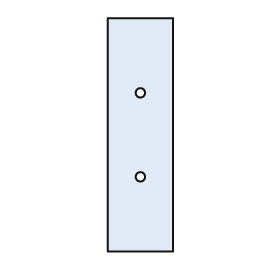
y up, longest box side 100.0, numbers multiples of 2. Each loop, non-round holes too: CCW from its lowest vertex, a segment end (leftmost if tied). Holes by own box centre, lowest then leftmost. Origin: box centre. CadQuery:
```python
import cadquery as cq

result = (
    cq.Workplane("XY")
    .moveTo(-14.0, -50.0)
    .lineTo(14.0, -50.0)
    .lineTo(14.0, 50.0)
    .lineTo(-14.0, 50.0)
    .close()
    .moveTo(0.0, -18.0)
    .circle(2.0)
    .moveTo(0.0, 18.0)
    .circle(2.0)
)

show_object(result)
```